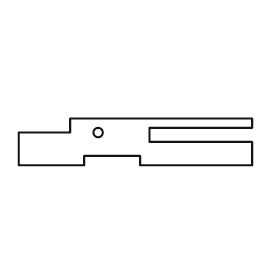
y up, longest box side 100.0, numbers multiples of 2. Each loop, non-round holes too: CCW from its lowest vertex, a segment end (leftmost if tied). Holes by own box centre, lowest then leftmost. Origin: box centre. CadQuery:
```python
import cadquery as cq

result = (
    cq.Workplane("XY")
    .moveTo(-50.0, -10.0)
    .lineTo(-22.0, -10.0)
    .lineTo(-22.0, -6.0)
    .lineTo(2.0, -6.0)
    .lineTo(2.0, -10.0)
    .lineTo(50.0, -10.0)
    .lineTo(50.0, 0.0)
    .lineTo(6.0, 0.0)
    .lineTo(6.0, 6.0)
    .lineTo(50.0, 6.0)
    .lineTo(50.0, 10.0)
    .lineTo(-28.0, 10.0)
    .lineTo(-28.0, 4.0)
    .lineTo(-50.0, 4.0)
    .close()
    .moveTo(-16.0, 4.0)
    .circle(2.0)
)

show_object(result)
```